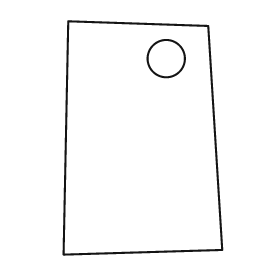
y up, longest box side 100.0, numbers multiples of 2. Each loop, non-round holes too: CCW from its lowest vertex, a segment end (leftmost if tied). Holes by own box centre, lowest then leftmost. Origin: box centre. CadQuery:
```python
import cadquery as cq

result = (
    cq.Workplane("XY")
    .moveTo(-34.0, -50.0)
    .lineTo(34.0, -48.0)
    .lineTo(28.0, 48.0)
    .lineTo(-32.0, 50.0)
    .close()
    .moveTo(10.0, 34.0)
    .circle(8.0)
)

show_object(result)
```